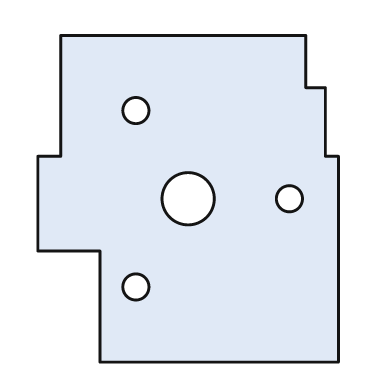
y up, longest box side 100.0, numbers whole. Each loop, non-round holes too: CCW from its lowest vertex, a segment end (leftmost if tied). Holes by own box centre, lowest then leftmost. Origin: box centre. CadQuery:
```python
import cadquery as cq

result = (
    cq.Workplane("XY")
    .moveTo(-27.0, -50.0)
    .lineTo(46.0, -50.0)
    .lineTo(46.0, 13.0)
    .lineTo(42.0, 13.0)
    .lineTo(42.0, 34.0)
    .lineTo(36.0, 34.0)
    .lineTo(36.0, 50.0)
    .lineTo(-39.0, 50.0)
    .lineTo(-39.0, 13.0)
    .lineTo(-46.0, 13.0)
    .lineTo(-46.0, -16.0)
    .lineTo(-27.0, -16.0)
    .close()
    .moveTo(-16.0, -27.0)
    .circle(4.0)
    .moveTo(0.0, 0.0)
    .circle(8.0)
    .moveTo(31.0, 0.0)
    .circle(4.0)
    .moveTo(-16.0, 27.0)
    .circle(4.0)
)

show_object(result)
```